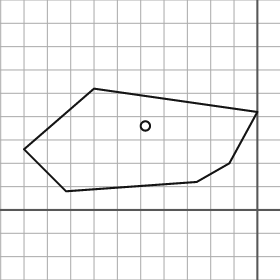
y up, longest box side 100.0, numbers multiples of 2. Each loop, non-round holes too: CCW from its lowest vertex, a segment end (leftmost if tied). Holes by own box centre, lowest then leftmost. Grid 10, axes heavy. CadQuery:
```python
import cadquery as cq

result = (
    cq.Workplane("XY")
    .moveTo(-82.0, 8.0)
    .lineTo(-26.0, 12.0)
    .lineTo(-12.0, 20.0)
    .lineTo(0.0, 42.0)
    .lineTo(-70.0, 52.0)
    .lineTo(-100.0, 26.0)
    .close()
    .moveTo(-48.0, 36.0)
    .circle(2.0)
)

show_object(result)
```